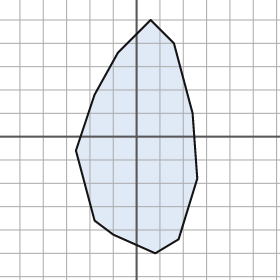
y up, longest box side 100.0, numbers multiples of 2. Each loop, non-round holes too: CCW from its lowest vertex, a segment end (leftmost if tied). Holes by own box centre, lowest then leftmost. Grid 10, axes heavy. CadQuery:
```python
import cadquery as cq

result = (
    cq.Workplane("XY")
    .moveTo(8.0, -50.0)
    .lineTo(18.0, -44.0)
    .lineTo(26.0, -18.0)
    .lineTo(24.0, 10.0)
    .lineTo(16.0, 40.0)
    .lineTo(6.0, 50.0)
    .lineTo(-8.0, 36.0)
    .lineTo(-18.0, 18.0)
    .lineTo(-26.0, -6.0)
    .lineTo(-18.0, -36.0)
    .lineTo(-10.0, -42.0)
    .close()
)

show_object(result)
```